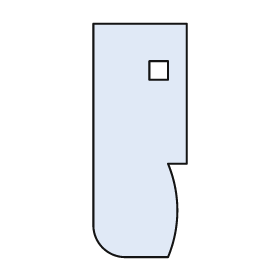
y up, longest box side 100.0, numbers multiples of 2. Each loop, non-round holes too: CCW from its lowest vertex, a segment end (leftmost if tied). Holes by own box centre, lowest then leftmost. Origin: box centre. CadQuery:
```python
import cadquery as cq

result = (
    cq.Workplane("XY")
    .moveTo(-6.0, -50.0)
    .lineTo(12.0, -50.0)
    .threePointArc((16.0, -30.0), (12.0, -10.0))
    .lineTo(20.0, -10.0)
    .lineTo(20.0, 50.0)
    .lineTo(-20.0, 50.0)
    .lineTo(-20.0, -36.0)
    .threePointArc((-16.0, -46.0), (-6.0, -50.0))
    .close()
    .moveTo(4.0, 26.0)
    .lineTo(12.0, 26.0)
    .lineTo(12.0, 34.0)
    .lineTo(4.0, 34.0)
    .close()
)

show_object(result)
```